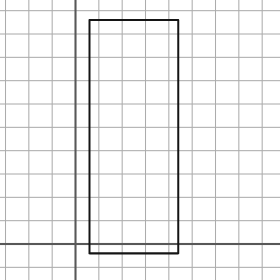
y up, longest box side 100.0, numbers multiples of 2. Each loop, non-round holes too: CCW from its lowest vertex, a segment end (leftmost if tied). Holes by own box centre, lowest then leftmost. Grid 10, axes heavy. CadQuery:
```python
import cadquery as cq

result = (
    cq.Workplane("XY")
    .moveTo(6.0, -4.0)
    .lineTo(44.0, -4.0)
    .lineTo(44.0, 96.0)
    .lineTo(6.0, 96.0)
    .close()
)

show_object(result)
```